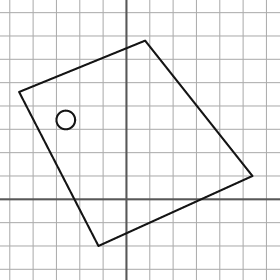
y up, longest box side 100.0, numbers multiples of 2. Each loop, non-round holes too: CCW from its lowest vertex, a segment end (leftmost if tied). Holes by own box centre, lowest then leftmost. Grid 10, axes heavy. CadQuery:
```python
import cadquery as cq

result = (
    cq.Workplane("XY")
    .moveTo(-12.0, -20.0)
    .lineTo(54.0, 10.0)
    .lineTo(8.0, 68.0)
    .lineTo(-46.0, 46.0)
    .close()
    .moveTo(-26.0, 34.0)
    .circle(4.0)
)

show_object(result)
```